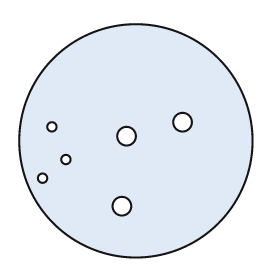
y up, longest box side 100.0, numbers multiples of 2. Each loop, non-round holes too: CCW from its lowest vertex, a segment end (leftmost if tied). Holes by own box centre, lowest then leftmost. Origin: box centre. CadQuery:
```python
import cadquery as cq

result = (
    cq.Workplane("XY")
    .moveTo(0.0, 0.0)
    .circle(50.0)
    .moveTo(-6.0, -28.0)
    .circle(4.0)
    .moveTo(-40.0, -16.0)
    .circle(2.0)
    .moveTo(-30.0, -8.0)
    .circle(2.0)
    .moveTo(-4.0, 2.0)
    .circle(4.0)
    .moveTo(-36.0, 6.0)
    .circle(2.0)
    .moveTo(20.0, 8.0)
    .circle(4.0)
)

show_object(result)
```